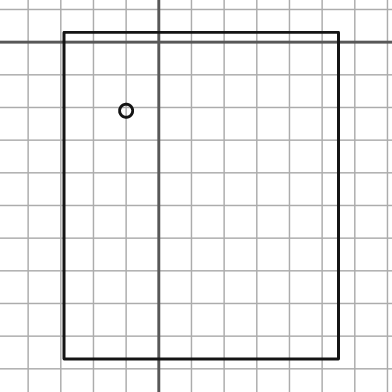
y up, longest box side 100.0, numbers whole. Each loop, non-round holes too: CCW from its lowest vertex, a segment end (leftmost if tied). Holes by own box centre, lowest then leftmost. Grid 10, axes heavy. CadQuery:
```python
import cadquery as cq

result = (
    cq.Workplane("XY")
    .moveTo(-29.0, -97.0)
    .lineTo(55.0, -97.0)
    .lineTo(55.0, 3.0)
    .lineTo(-29.0, 3.0)
    .close()
    .moveTo(-10.0, -21.0)
    .circle(2.0)
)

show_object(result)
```